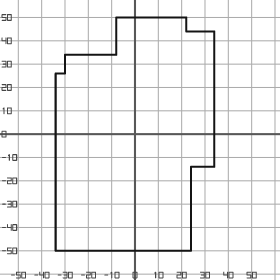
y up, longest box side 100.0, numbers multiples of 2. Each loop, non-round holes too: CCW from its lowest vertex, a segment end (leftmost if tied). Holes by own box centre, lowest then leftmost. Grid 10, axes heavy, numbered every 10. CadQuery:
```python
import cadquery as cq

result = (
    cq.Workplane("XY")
    .moveTo(-34.0, -50.0)
    .lineTo(24.0, -50.0)
    .lineTo(24.0, -14.0)
    .lineTo(34.0, -14.0)
    .lineTo(34.0, 44.0)
    .lineTo(22.0, 44.0)
    .lineTo(22.0, 50.0)
    .lineTo(-8.0, 50.0)
    .lineTo(-8.0, 34.0)
    .lineTo(-30.0, 34.0)
    .lineTo(-30.0, 26.0)
    .lineTo(-34.0, 26.0)
    .close()
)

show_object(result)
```